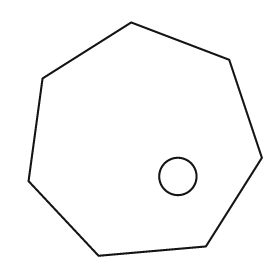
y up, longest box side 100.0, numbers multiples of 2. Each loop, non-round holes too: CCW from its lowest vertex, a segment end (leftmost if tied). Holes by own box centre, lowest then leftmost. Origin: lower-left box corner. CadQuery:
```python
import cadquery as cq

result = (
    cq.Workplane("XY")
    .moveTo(30.0, 0.0)
    .lineTo(76.0, 4.0)
    .lineTo(100.0, 42.0)
    .lineTo(86.0, 84.0)
    .lineTo(44.0, 100.0)
    .lineTo(6.0, 76.0)
    .lineTo(0.0, 32.0)
    .close()
    .moveTo(64.0, 34.0)
    .circle(8.0)
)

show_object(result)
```